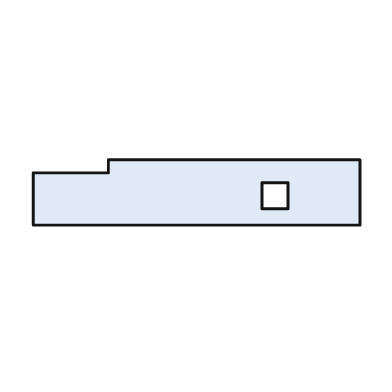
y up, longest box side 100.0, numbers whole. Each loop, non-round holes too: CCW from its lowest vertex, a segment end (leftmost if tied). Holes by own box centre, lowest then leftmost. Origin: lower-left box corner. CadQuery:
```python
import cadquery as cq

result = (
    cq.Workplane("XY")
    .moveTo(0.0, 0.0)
    .lineTo(100.0, 0.0)
    .lineTo(100.0, 20.0)
    .lineTo(23.0, 20.0)
    .lineTo(23.0, 16.0)
    .lineTo(0.0, 16.0)
    .close()
    .moveTo(70.0, 5.0)
    .lineTo(78.0, 5.0)
    .lineTo(78.0, 13.0)
    .lineTo(70.0, 13.0)
    .close()
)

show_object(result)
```